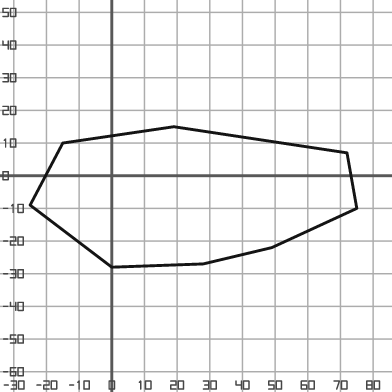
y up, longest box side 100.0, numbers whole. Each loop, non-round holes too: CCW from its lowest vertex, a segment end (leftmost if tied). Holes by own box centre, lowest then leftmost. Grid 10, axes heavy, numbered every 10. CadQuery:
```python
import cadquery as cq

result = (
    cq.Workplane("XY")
    .moveTo(0.0, -28.0)
    .lineTo(28.0, -27.0)
    .lineTo(49.0, -22.0)
    .lineTo(75.0, -10.0)
    .lineTo(72.0, 7.0)
    .lineTo(19.0, 15.0)
    .lineTo(-15.0, 10.0)
    .lineTo(-25.0, -9.0)
    .close()
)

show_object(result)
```